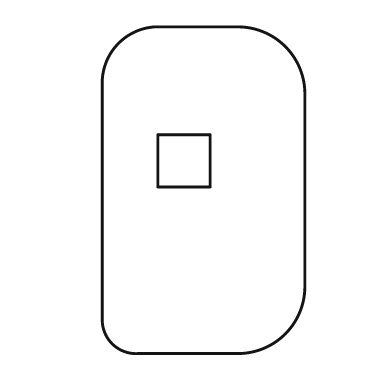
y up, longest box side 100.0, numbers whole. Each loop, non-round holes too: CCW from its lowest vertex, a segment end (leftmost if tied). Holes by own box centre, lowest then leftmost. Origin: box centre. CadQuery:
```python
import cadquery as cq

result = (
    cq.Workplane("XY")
    .moveTo(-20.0, -50.0)
    .lineTo(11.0, -50.0)
    .threePointArc((25.0, -44.0), (31.0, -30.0))
    .lineTo(31.0, 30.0)
    .threePointArc((25.0, 44.0), (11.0, 50.0))
    .lineTo(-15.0, 50.0)
    .threePointArc((-26.0, 45.0), (-31.0, 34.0))
    .lineTo(-31.0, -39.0)
    .threePointArc((-28.0, -47.0), (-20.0, -50.0))
    .close()
    .moveTo(-14.0, 1.0)
    .lineTo(2.0, 1.0)
    .lineTo(2.0, 17.0)
    .lineTo(-14.0, 17.0)
    .close()
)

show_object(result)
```